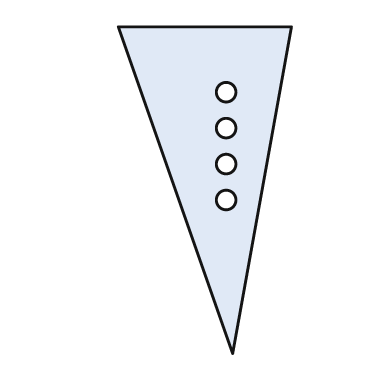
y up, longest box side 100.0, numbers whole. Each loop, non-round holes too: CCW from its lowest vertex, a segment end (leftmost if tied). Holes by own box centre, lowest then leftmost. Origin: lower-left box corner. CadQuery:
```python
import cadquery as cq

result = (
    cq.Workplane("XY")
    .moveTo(35.0, 0.0)
    .lineTo(53.0, 100.0)
    .lineTo(0.0, 100.0)
    .close()
    .moveTo(33.0, 47.0)
    .circle(3.0)
    .moveTo(33.0, 58.0)
    .circle(3.0)
    .moveTo(33.0, 69.0)
    .circle(3.0)
    .moveTo(33.0, 80.0)
    .circle(3.0)
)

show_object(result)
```